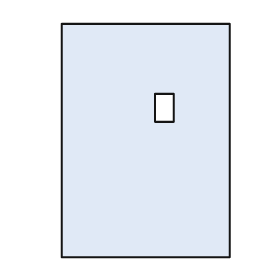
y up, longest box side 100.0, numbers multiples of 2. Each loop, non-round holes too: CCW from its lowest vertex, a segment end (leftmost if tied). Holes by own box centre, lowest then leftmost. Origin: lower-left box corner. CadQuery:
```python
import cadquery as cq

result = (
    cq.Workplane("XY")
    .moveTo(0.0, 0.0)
    .lineTo(72.0, 0.0)
    .lineTo(72.0, 100.0)
    .lineTo(0.0, 100.0)
    .close()
    .moveTo(40.0, 58.0)
    .lineTo(48.0, 58.0)
    .lineTo(48.0, 70.0)
    .lineTo(40.0, 70.0)
    .close()
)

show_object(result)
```